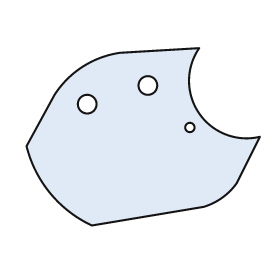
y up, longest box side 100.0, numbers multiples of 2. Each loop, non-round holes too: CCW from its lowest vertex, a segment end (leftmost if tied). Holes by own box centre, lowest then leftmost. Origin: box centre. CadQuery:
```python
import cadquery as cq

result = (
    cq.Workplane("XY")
    .moveTo(-22.0, -38.0)
    .lineTo(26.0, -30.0)
    .threePointArc((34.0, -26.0), (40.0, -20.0))
    .lineTo(50.0, 0.0)
    .threePointArc((24.0, 10.0), (24.0, 38.0))
    .lineTo(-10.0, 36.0)
    .threePointArc((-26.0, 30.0), (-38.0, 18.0))
    .lineTo(-50.0, -4.0)
    .threePointArc((-40.0, -24.0), (-22.0, -38.0))
    .close()
    .moveTo(20.0, 4.0)
    .circle(2.0)
    .moveTo(-24.0, 14.0)
    .circle(4.0)
    .moveTo(2.0, 22.0)
    .circle(4.0)
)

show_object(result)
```